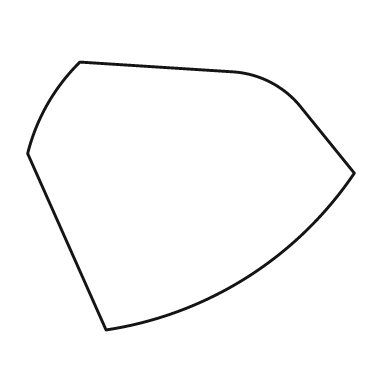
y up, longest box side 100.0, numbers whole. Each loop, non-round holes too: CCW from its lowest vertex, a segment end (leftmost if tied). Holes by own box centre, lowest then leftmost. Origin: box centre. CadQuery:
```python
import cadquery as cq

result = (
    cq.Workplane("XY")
    .moveTo(-26.0, -41.0)
    .threePointArc((17.0, -25.0), (50.0, 7.0))
    .lineTo(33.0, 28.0)
    .threePointArc((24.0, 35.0), (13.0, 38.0))
    .lineTo(-34.0, 41.0)
    .threePointArc((-44.0, 28.0), (-50.0, 13.0))
    .close()
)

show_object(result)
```